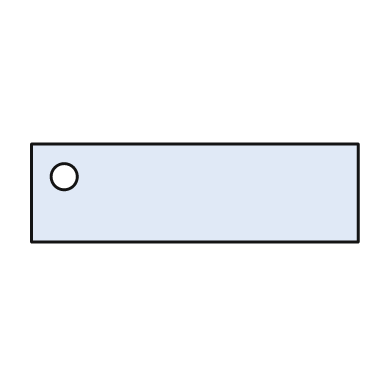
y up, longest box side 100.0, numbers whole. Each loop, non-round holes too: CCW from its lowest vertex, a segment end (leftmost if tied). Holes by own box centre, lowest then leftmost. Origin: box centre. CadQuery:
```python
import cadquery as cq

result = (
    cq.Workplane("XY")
    .moveTo(-50.0, -15.0)
    .lineTo(50.0, -15.0)
    .lineTo(50.0, 15.0)
    .lineTo(-50.0, 15.0)
    .close()
    .moveTo(-40.0, 5.0)
    .circle(4.0)
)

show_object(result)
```